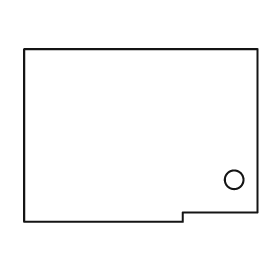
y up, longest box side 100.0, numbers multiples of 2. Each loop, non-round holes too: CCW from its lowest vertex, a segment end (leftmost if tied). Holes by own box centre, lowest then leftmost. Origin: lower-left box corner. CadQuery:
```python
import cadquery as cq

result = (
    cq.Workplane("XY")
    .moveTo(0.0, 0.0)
    .lineTo(68.0, 0.0)
    .lineTo(68.0, 4.0)
    .lineTo(100.0, 4.0)
    .lineTo(100.0, 74.0)
    .lineTo(0.0, 74.0)
    .close()
    .moveTo(90.0, 18.0)
    .circle(4.0)
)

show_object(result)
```